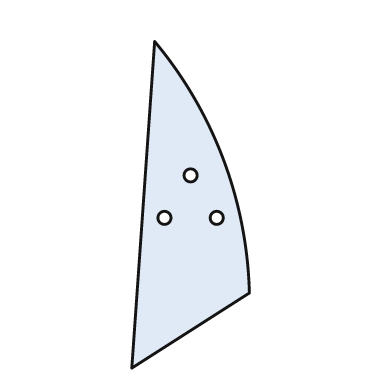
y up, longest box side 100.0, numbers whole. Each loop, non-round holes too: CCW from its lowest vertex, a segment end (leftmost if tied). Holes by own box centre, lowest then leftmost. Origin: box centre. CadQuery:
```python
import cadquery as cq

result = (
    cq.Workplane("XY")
    .moveTo(-18.0, -50.0)
    .lineTo(18.0, -27.0)
    .threePointArc((10.0, 14.0), (-11.0, 50.0))
    .close()
    .moveTo(-8.0, -4.0)
    .circle(2.0)
    .moveTo(8.0, -4.0)
    .circle(2.0)
    .moveTo(0.0, 9.0)
    .circle(2.0)
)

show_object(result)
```